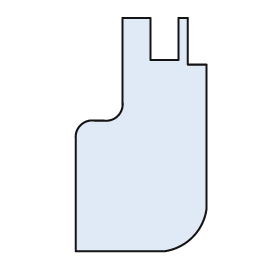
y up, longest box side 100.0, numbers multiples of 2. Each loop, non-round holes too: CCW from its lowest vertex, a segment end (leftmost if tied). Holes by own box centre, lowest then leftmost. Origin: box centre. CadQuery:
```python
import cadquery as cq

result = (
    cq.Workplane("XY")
    .moveTo(-28.0, -50.0)
    .lineTo(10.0, -50.0)
    .threePointArc((22.0, -44.0), (28.0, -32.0))
    .lineTo(28.0, 30.0)
    .lineTo(20.0, 30.0)
    .lineTo(20.0, 50.0)
    .lineTo(16.0, 50.0)
    .lineTo(16.0, 32.0)
    .lineTo(4.0, 32.0)
    .lineTo(4.0, 50.0)
    .lineTo(-8.0, 50.0)
    .lineTo(-8.0, 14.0)
    .threePointArc((-10.0, 8.0), (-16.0, 6.0))
    .lineTo(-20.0, 6.0)
    .threePointArc((-26.0, 4.0), (-28.0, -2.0))
    .close()
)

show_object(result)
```